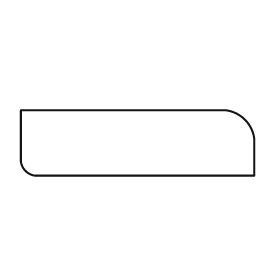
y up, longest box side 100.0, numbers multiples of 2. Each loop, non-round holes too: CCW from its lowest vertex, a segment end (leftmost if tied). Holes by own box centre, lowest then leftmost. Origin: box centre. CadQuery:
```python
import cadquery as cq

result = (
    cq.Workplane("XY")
    .moveTo(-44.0, -14.0)
    .lineTo(50.0, -14.0)
    .lineTo(50.0, 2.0)
    .threePointArc((46.0, 10.0), (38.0, 14.0))
    .lineTo(-50.0, 14.0)
    .lineTo(-50.0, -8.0)
    .threePointArc((-48.0, -12.0), (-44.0, -14.0))
    .close()
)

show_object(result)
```